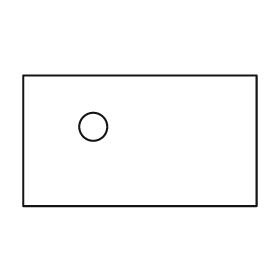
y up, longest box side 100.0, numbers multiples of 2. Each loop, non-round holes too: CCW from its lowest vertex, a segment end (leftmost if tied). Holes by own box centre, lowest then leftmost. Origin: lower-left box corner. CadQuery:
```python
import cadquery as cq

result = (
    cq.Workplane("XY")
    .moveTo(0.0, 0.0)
    .lineTo(100.0, 0.0)
    .lineTo(100.0, 56.0)
    .lineTo(0.0, 56.0)
    .close()
    .moveTo(30.0, 34.0)
    .circle(6.0)
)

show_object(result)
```